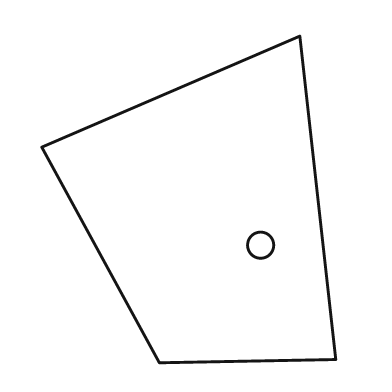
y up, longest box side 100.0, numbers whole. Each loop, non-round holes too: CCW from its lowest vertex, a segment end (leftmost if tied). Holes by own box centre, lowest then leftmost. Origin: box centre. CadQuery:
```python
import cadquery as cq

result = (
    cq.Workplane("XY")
    .moveTo(-9.0, -50.0)
    .lineTo(45.0, -49.0)
    .lineTo(34.0, 50.0)
    .lineTo(-45.0, 16.0)
    .close()
    .moveTo(22.0, -14.0)
    .circle(4.0)
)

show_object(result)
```